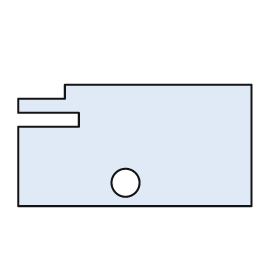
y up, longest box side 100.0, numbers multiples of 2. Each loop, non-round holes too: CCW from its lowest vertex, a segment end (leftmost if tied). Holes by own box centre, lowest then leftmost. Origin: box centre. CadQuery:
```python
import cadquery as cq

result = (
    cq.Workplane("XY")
    .moveTo(-50.0, -26.0)
    .lineTo(50.0, -26.0)
    .lineTo(50.0, 26.0)
    .lineTo(-30.0, 26.0)
    .lineTo(-30.0, 20.0)
    .lineTo(-50.0, 20.0)
    .lineTo(-50.0, 14.0)
    .lineTo(-24.0, 14.0)
    .lineTo(-24.0, 8.0)
    .lineTo(-50.0, 8.0)
    .close()
    .moveTo(-4.0, -16.0)
    .circle(6.0)
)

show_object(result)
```